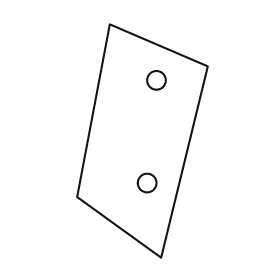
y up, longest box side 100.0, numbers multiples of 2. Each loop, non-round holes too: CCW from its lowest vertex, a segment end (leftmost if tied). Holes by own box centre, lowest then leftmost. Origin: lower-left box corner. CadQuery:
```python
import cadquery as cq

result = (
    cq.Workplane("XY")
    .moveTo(36.0, 0.0)
    .lineTo(56.0, 82.0)
    .lineTo(14.0, 100.0)
    .lineTo(0.0, 26.0)
    .close()
    .moveTo(30.0, 32.0)
    .circle(4.0)
    .moveTo(34.0, 76.0)
    .circle(4.0)
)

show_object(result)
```